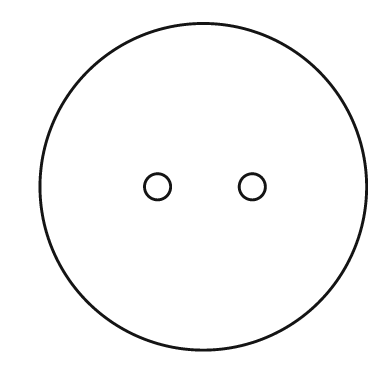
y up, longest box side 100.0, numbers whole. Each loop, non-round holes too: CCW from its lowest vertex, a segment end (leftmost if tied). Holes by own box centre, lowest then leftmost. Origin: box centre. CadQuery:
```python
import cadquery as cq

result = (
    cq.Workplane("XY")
    .moveTo(0.0, 0.0)
    .circle(50.0)
    .moveTo(-14.0, 0.0)
    .circle(4.0)
    .moveTo(15.0, 0.0)
    .circle(4.0)
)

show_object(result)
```